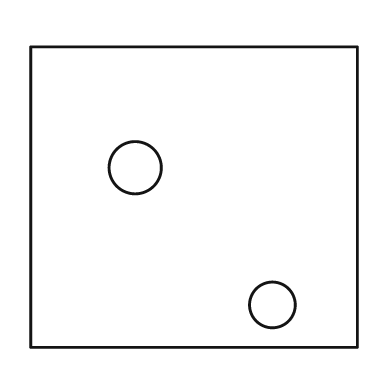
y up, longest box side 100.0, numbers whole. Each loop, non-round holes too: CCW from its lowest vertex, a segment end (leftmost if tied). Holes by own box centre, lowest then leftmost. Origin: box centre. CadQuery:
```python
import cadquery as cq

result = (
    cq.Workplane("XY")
    .moveTo(-50.0, -46.0)
    .lineTo(50.0, -46.0)
    .lineTo(50.0, 46.0)
    .lineTo(-50.0, 46.0)
    .close()
    .moveTo(24.0, -33.0)
    .circle(7.0)
    .moveTo(-18.0, 9.0)
    .circle(8.0)
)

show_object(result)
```